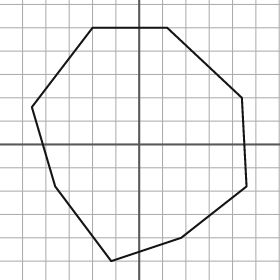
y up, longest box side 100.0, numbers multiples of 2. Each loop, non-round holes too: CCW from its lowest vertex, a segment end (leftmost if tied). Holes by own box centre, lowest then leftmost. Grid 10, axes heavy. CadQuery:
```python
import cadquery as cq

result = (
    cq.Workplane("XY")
    .moveTo(-12.0, -50.0)
    .lineTo(18.0, -40.0)
    .lineTo(46.0, -18.0)
    .lineTo(44.0, 20.0)
    .lineTo(12.0, 50.0)
    .lineTo(-20.0, 50.0)
    .lineTo(-46.0, 16.0)
    .lineTo(-36.0, -18.0)
    .close()
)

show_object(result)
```